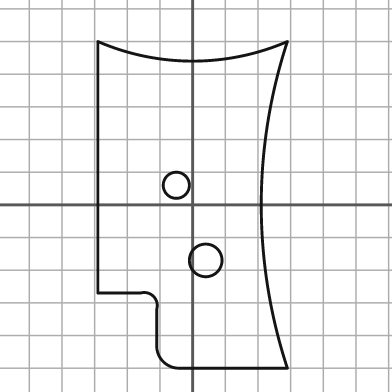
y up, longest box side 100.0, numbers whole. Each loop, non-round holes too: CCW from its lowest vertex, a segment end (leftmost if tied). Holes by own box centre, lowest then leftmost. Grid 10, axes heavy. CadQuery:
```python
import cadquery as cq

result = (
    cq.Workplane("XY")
    .moveTo(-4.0, -50.0)
    .lineTo(29.0, -50.0)
    .threePointArc((21.0, 0.0), (29.0, 50.0))
    .threePointArc((0.0, 44.0), (-29.0, 50.0))
    .lineTo(-29.0, -27.0)
    .lineTo(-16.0, -27.0)
    .threePointArc((-12.0, -28.0), (-11.0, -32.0))
    .lineTo(-11.0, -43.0)
    .threePointArc((-9.0, -48.0), (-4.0, -50.0))
    .close()
    .moveTo(4.0, -17.0)
    .circle(5.0)
    .moveTo(-5.0, 6.0)
    .circle(4.0)
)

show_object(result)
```